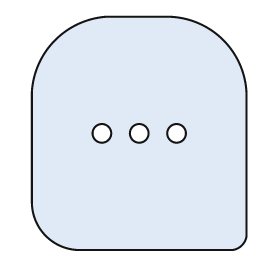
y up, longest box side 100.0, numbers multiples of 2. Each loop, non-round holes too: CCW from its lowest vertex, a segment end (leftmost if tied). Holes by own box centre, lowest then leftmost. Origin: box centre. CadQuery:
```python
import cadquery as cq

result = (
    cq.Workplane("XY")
    .moveTo(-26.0, -50.0)
    .lineTo(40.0, -50.0)
    .threePointArc((44.0, -48.0), (46.0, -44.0))
    .lineTo(46.0, 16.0)
    .threePointArc((36.0, 40.0), (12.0, 50.0))
    .lineTo(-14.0, 50.0)
    .threePointArc((-36.0, 40.0), (-46.0, 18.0))
    .lineTo(-46.0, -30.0)
    .threePointArc((-40.0, -44.0), (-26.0, -50.0))
    .close()
    .moveTo(-16.0, 0.0)
    .circle(4.0)
    .moveTo(0.0, 0.0)
    .circle(4.0)
    .moveTo(16.0, 0.0)
    .circle(4.0)
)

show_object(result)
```